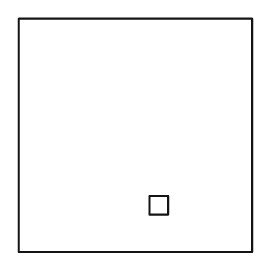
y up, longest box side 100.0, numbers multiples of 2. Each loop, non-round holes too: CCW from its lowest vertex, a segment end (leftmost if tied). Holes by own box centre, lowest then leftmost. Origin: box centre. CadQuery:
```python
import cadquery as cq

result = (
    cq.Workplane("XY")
    .moveTo(-50.0, -50.0)
    .lineTo(50.0, -50.0)
    .lineTo(50.0, 50.0)
    .lineTo(-50.0, 50.0)
    .close()
    .moveTo(6.0, -34.0)
    .lineTo(14.0, -34.0)
    .lineTo(14.0, -26.0)
    .lineTo(6.0, -26.0)
    .close()
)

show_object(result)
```